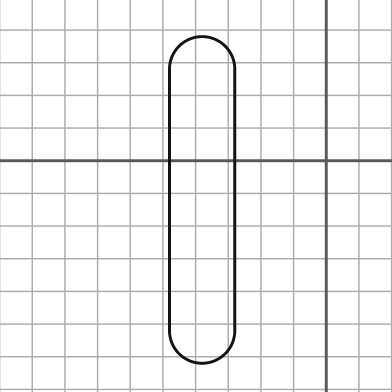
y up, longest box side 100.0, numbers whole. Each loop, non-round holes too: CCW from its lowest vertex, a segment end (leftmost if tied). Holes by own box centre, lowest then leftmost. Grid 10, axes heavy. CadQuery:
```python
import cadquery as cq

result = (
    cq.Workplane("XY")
    .moveTo(-48.0, -52.0)
    .threePointArc((-38.0, -62.0), (-28.0, -52.0))
    .lineTo(-28.0, 28.0)
    .threePointArc((-38.0, 38.0), (-48.0, 28.0))
    .close()
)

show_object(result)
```